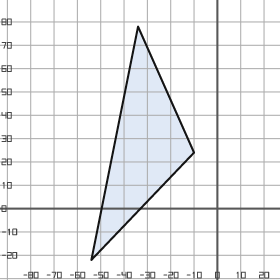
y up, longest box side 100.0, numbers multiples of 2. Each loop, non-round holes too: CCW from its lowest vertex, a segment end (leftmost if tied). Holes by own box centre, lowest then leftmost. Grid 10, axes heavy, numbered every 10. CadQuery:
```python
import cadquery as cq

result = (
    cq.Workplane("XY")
    .moveTo(-54.0, -22.0)
    .lineTo(-10.0, 24.0)
    .lineTo(-34.0, 78.0)
    .close()
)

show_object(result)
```